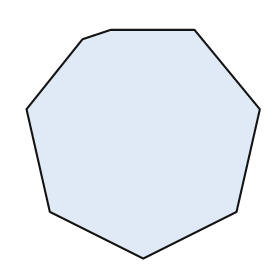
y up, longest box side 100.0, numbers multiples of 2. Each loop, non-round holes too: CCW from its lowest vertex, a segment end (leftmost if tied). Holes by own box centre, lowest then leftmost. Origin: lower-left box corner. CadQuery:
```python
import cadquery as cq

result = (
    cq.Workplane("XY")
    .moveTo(50.0, 0.0)
    .lineTo(90.0, 20.0)
    .lineTo(100.0, 64.0)
    .lineTo(72.0, 98.0)
    .lineTo(36.0, 98.0)
    .lineTo(24.0, 94.0)
    .lineTo(0.0, 64.0)
    .lineTo(10.0, 20.0)
    .close()
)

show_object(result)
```